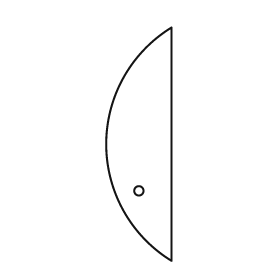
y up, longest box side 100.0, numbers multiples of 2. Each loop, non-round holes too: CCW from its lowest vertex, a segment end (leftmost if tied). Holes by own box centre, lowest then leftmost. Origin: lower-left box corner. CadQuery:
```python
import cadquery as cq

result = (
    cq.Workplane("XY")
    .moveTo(28.0, 0.0)
    .lineTo(28.0, 100.0)
    .threePointArc((0.0, 50.0), (28.0, 0.0))
    .close()
    .moveTo(14.0, 30.0)
    .circle(2.0)
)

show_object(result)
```